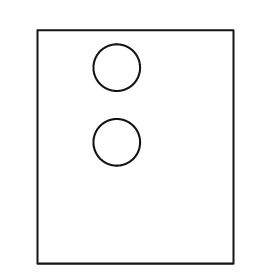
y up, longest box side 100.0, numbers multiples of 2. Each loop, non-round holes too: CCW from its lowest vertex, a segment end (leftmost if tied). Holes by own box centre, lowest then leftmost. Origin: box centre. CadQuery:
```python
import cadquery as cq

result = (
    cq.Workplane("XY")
    .moveTo(-42.0, -50.0)
    .lineTo(42.0, -50.0)
    .lineTo(42.0, 50.0)
    .lineTo(-42.0, 50.0)
    .close()
    .moveTo(-8.0, 2.0)
    .circle(10.0)
    .moveTo(-8.0, 34.0)
    .circle(10.0)
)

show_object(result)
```